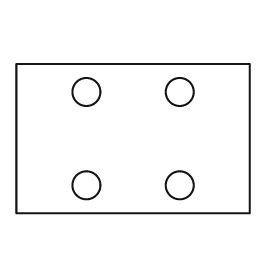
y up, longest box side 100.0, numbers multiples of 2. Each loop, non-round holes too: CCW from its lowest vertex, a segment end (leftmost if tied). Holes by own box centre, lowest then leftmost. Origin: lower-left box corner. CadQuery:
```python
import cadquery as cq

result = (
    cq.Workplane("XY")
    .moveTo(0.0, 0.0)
    .lineTo(100.0, 0.0)
    .lineTo(100.0, 64.0)
    .lineTo(0.0, 64.0)
    .close()
    .moveTo(30.0, 12.0)
    .circle(6.0)
    .moveTo(70.0, 12.0)
    .circle(6.0)
    .moveTo(30.0, 52.0)
    .circle(6.0)
    .moveTo(70.0, 52.0)
    .circle(6.0)
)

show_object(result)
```